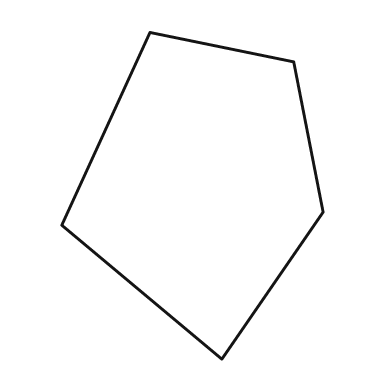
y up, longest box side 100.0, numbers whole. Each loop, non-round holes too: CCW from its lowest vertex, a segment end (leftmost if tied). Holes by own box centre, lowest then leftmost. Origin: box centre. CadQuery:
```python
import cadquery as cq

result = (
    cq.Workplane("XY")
    .moveTo(9.0, -50.0)
    .lineTo(40.0, -5.0)
    .lineTo(31.0, 41.0)
    .lineTo(-13.0, 50.0)
    .lineTo(-40.0, -9.0)
    .close()
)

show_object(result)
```